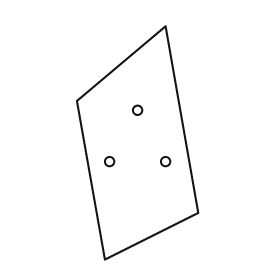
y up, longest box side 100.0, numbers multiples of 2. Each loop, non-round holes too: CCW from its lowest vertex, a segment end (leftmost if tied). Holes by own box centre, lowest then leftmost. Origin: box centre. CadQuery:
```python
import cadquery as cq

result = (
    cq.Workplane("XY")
    .moveTo(-14.0, -50.0)
    .lineTo(26.0, -30.0)
    .lineTo(12.0, 50.0)
    .lineTo(-26.0, 18.0)
    .close()
    .moveTo(-12.0, -8.0)
    .circle(2.0)
    .moveTo(12.0, -8.0)
    .circle(2.0)
    .moveTo(0.0, 14.0)
    .circle(2.0)
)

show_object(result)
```